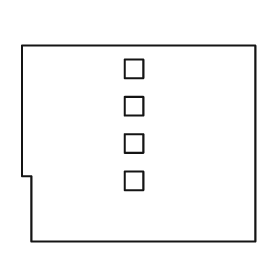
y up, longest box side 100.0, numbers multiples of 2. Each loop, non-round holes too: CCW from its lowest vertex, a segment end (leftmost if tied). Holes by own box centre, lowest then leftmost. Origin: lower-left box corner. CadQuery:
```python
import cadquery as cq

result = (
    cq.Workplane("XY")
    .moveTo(4.0, 0.0)
    .lineTo(100.0, 0.0)
    .lineTo(100.0, 84.0)
    .lineTo(0.0, 84.0)
    .lineTo(0.0, 28.0)
    .lineTo(4.0, 28.0)
    .close()
    .moveTo(44.0, 22.0)
    .lineTo(52.0, 22.0)
    .lineTo(52.0, 30.0)
    .lineTo(44.0, 30.0)
    .close()
    .moveTo(44.0, 38.0)
    .lineTo(52.0, 38.0)
    .lineTo(52.0, 46.0)
    .lineTo(44.0, 46.0)
    .close()
    .moveTo(44.0, 54.0)
    .lineTo(52.0, 54.0)
    .lineTo(52.0, 62.0)
    .lineTo(44.0, 62.0)
    .close()
    .moveTo(44.0, 70.0)
    .lineTo(52.0, 70.0)
    .lineTo(52.0, 78.0)
    .lineTo(44.0, 78.0)
    .close()
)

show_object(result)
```